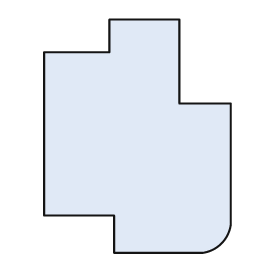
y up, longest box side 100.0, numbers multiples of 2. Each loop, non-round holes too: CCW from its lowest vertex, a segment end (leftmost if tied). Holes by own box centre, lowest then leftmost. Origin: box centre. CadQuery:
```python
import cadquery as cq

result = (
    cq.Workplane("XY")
    .moveTo(-10.0, -50.0)
    .lineTo(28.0, -50.0)
    .threePointArc((36.0, -46.0), (40.0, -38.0))
    .lineTo(40.0, 14.0)
    .lineTo(18.0, 14.0)
    .lineTo(18.0, 50.0)
    .lineTo(-12.0, 50.0)
    .lineTo(-12.0, 36.0)
    .lineTo(-40.0, 36.0)
    .lineTo(-40.0, -34.0)
    .lineTo(-10.0, -34.0)
    .close()
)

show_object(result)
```